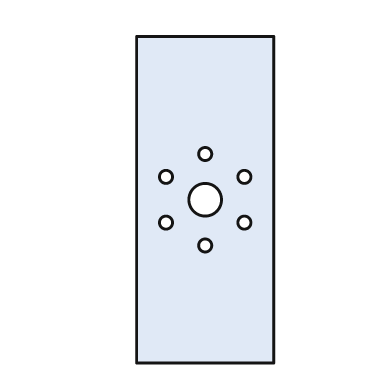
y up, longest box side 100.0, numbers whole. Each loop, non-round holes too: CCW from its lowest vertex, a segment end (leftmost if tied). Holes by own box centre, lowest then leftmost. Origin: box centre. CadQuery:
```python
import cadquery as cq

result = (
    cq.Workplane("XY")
    .moveTo(-21.0, -50.0)
    .lineTo(21.0, -50.0)
    .lineTo(21.0, 50.0)
    .lineTo(-21.0, 50.0)
    .close()
    .moveTo(0.0, -14.0)
    .circle(2.0)
    .moveTo(-12.0, -7.0)
    .circle(2.0)
    .moveTo(12.0, -7.0)
    .circle(2.0)
    .moveTo(0.0, 0.0)
    .circle(5.0)
    .moveTo(-12.0, 7.0)
    .circle(2.0)
    .moveTo(12.0, 7.0)
    .circle(2.0)
    .moveTo(0.0, 14.0)
    .circle(2.0)
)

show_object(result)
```